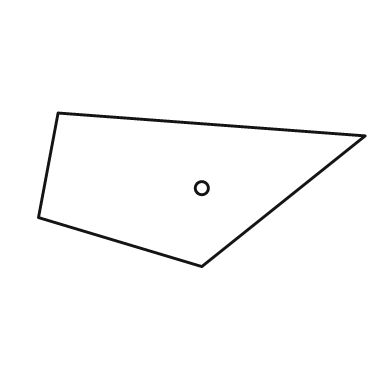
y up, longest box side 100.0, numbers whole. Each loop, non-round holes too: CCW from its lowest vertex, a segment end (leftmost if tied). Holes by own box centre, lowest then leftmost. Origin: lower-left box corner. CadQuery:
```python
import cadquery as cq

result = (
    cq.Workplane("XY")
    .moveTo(50.0, 0.0)
    .lineTo(100.0, 40.0)
    .lineTo(6.0, 47.0)
    .lineTo(0.0, 15.0)
    .close()
    .moveTo(50.0, 24.0)
    .circle(2.0)
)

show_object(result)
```